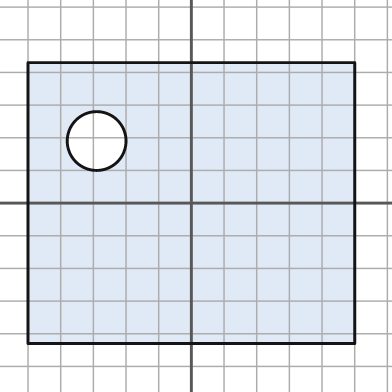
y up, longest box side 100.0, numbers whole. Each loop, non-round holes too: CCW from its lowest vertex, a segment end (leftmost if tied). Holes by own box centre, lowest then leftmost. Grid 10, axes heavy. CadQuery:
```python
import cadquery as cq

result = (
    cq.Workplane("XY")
    .moveTo(-50.0, -43.0)
    .lineTo(50.0, -43.0)
    .lineTo(50.0, 43.0)
    .lineTo(-50.0, 43.0)
    .close()
    .moveTo(-29.0, 19.0)
    .circle(9.0)
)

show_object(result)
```